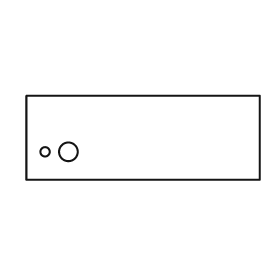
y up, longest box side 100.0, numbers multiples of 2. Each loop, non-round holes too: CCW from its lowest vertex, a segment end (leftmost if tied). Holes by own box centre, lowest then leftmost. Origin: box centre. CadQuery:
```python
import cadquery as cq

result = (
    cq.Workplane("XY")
    .moveTo(-50.0, -18.0)
    .lineTo(50.0, -18.0)
    .lineTo(50.0, 18.0)
    .lineTo(-50.0, 18.0)
    .close()
    .moveTo(-42.0, -6.0)
    .circle(2.0)
    .moveTo(-32.0, -6.0)
    .circle(4.0)
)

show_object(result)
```